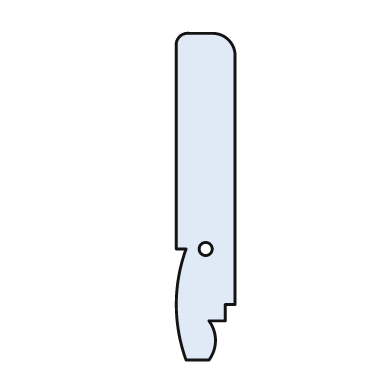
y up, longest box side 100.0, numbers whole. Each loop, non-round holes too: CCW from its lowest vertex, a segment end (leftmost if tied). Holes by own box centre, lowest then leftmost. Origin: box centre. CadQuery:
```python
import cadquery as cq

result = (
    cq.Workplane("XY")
    .moveTo(-6.0, -50.0)
    .lineTo(1.0, -50.0)
    .threePointArc((3.0, -44.0), (1.0, -38.0))
    .lineTo(6.0, -38.0)
    .lineTo(6.0, -33.0)
    .lineTo(9.0, -33.0)
    .lineTo(9.0, 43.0)
    .threePointArc((7.0, 48.0), (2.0, 50.0))
    .lineTo(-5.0, 50.0)
    .threePointArc((-8.0, 49.0), (-9.0, 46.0))
    .lineTo(-9.0, -16.0)
    .lineTo(-6.0, -16.0)
    .threePointArc((-9.0, -33.0), (-6.0, -50.0))
    .close()
    .moveTo(0.0, -16.0)
    .circle(2.0)
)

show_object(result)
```